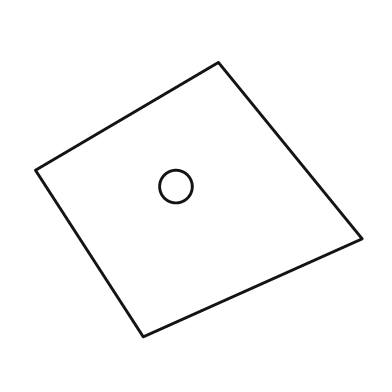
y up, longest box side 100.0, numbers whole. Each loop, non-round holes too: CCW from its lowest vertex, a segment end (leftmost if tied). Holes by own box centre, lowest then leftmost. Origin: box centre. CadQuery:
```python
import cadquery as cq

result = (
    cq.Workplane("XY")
    .moveTo(-17.0, -42.0)
    .lineTo(50.0, -12.0)
    .lineTo(6.0, 42.0)
    .lineTo(-50.0, 9.0)
    .close()
    .moveTo(-7.0, 4.0)
    .circle(5.0)
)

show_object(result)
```